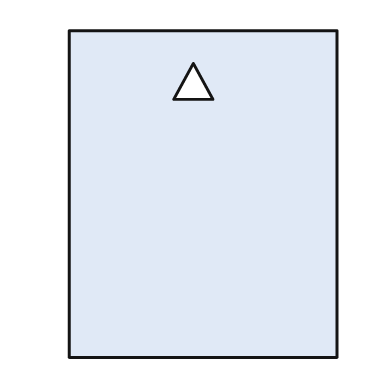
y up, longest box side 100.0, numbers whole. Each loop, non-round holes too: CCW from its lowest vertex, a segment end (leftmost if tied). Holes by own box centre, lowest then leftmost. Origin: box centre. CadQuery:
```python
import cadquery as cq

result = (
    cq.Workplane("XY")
    .moveTo(-41.0, -50.0)
    .lineTo(41.0, -50.0)
    .lineTo(41.0, 50.0)
    .lineTo(-41.0, 50.0)
    .close()
    .moveTo(-9.0, 29.0)
    .lineTo(3.0, 29.0)
    .lineTo(-3.0, 40.0)
    .close()
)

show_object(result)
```